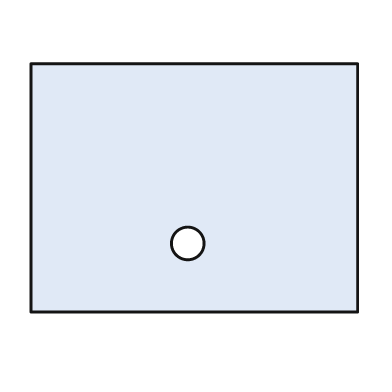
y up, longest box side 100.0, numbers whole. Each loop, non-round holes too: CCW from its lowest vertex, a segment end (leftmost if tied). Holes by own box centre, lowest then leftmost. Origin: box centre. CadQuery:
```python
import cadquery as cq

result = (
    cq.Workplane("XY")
    .moveTo(-50.0, -38.0)
    .lineTo(50.0, -38.0)
    .lineTo(50.0, 38.0)
    .lineTo(-50.0, 38.0)
    .close()
    .moveTo(-2.0, -17.0)
    .circle(5.0)
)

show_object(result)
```